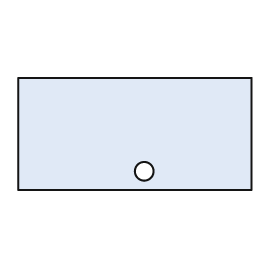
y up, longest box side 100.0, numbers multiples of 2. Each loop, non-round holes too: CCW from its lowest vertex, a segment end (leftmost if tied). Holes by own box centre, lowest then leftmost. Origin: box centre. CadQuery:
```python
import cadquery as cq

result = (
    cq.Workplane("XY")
    .moveTo(-50.0, -24.0)
    .lineTo(50.0, -24.0)
    .lineTo(50.0, 24.0)
    .lineTo(-50.0, 24.0)
    .close()
    .moveTo(4.0, -16.0)
    .circle(4.0)
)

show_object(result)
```